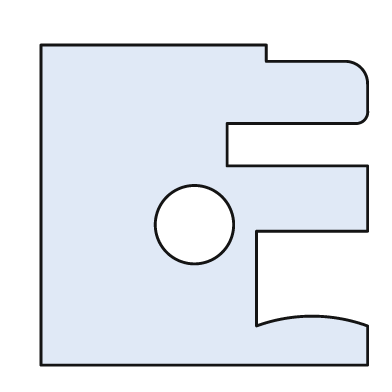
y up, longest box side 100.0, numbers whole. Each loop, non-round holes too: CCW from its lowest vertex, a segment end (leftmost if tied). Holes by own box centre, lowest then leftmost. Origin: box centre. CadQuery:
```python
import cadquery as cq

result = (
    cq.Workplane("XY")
    .moveTo(-50.0, -49.0)
    .lineTo(50.0, -49.0)
    .lineTo(50.0, -37.0)
    .threePointArc((33.0, -34.0), (16.0, -37.0))
    .lineTo(16.0, -8.0)
    .lineTo(50.0, -8.0)
    .lineTo(50.0, 12.0)
    .lineTo(7.0, 12.0)
    .lineTo(7.0, 25.0)
    .lineTo(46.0, 25.0)
    .threePointArc((49.0, 26.0), (50.0, 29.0))
    .lineTo(50.0, 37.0)
    .threePointArc((48.0, 42.0), (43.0, 44.0))
    .lineTo(19.0, 44.0)
    .lineTo(19.0, 49.0)
    .lineTo(-50.0, 49.0)
    .close()
    .moveTo(-3.0, -6.0)
    .circle(12.0)
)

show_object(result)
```